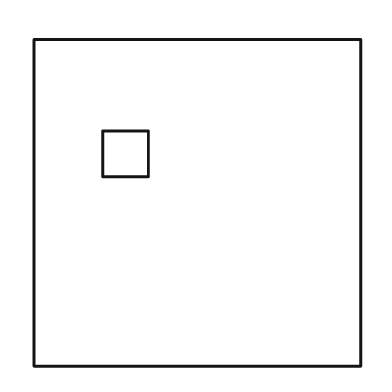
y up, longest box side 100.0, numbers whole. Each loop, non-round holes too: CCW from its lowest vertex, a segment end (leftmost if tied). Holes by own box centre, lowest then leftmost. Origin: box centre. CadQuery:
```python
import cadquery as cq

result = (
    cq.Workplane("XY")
    .moveTo(-50.0, -50.0)
    .lineTo(50.0, -50.0)
    .lineTo(50.0, 50.0)
    .lineTo(-50.0, 50.0)
    .close()
    .moveTo(-29.0, 8.0)
    .lineTo(-15.0, 8.0)
    .lineTo(-15.0, 22.0)
    .lineTo(-29.0, 22.0)
    .close()
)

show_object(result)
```